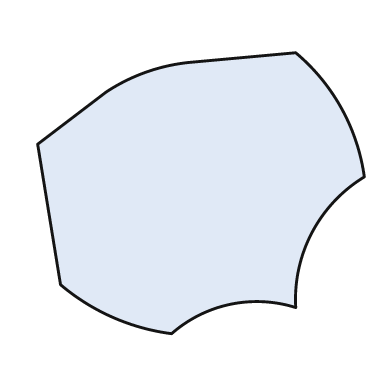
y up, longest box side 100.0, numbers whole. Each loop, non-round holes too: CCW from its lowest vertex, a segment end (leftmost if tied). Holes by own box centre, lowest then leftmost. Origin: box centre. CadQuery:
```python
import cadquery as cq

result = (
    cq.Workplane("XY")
    .moveTo(-9.0, -43.0)
    .threePointArc((9.0, -34.0), (29.0, -35.0))
    .threePointArc((34.0, -12.0), (50.0, 5.0))
    .threePointArc((43.0, 26.0), (29.0, 43.0))
    .lineTo(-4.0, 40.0)
    .threePointArc((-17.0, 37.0), (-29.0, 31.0))
    .lineTo(-50.0, 15.0)
    .lineTo(-43.0, -28.0)
    .threePointArc((-27.0, -38.0), (-9.0, -43.0))
    .close()
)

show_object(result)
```